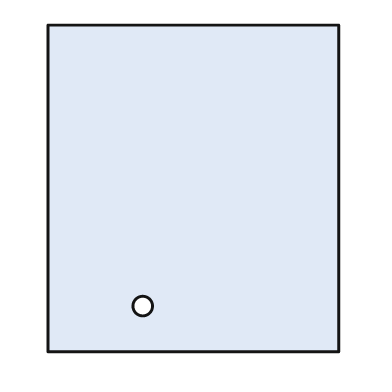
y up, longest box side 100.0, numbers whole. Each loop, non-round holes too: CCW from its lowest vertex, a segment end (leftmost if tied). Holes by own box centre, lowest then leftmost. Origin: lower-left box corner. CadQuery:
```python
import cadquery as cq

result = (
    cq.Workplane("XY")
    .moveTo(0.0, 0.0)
    .lineTo(89.0, 0.0)
    .lineTo(89.0, 100.0)
    .lineTo(0.0, 100.0)
    .close()
    .moveTo(29.0, 14.0)
    .circle(3.0)
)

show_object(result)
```